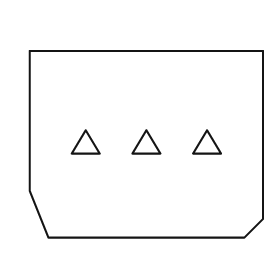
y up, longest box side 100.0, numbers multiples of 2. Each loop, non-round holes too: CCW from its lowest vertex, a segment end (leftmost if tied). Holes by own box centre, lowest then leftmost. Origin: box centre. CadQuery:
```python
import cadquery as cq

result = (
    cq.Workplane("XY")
    .moveTo(-42.0, -40.0)
    .lineTo(42.0, -40.0)
    .lineTo(50.0, -32.0)
    .lineTo(50.0, 40.0)
    .lineTo(-50.0, 40.0)
    .lineTo(-50.0, -20.0)
    .close()
    .moveTo(-32.0, -4.0)
    .lineTo(-20.0, -4.0)
    .lineTo(-26.0, 6.0)
    .close()
    .moveTo(-6.0, -4.0)
    .lineTo(6.0, -4.0)
    .lineTo(0.0, 6.0)
    .close()
    .moveTo(20.0, -4.0)
    .lineTo(32.0, -4.0)
    .lineTo(26.0, 6.0)
    .close()
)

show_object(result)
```